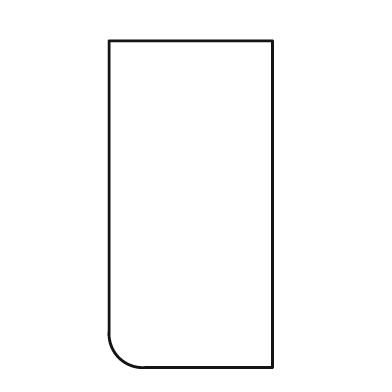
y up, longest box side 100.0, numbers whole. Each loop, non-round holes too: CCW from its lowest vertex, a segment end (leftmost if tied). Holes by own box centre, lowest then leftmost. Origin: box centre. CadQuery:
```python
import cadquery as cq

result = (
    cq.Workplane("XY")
    .moveTo(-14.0, -50.0)
    .lineTo(25.0, -50.0)
    .lineTo(25.0, 50.0)
    .lineTo(-25.0, 50.0)
    .lineTo(-25.0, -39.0)
    .threePointArc((-22.0, -47.0), (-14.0, -50.0))
    .close()
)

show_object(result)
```